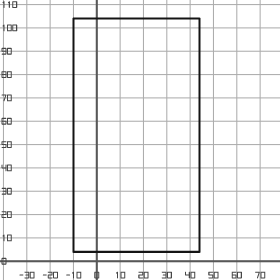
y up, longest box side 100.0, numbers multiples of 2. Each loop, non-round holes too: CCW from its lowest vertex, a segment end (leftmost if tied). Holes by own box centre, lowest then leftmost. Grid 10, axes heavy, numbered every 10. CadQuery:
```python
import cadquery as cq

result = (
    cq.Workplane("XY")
    .moveTo(-10.0, 4.0)
    .lineTo(44.0, 4.0)
    .lineTo(44.0, 104.0)
    .lineTo(-10.0, 104.0)
    .close()
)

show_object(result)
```